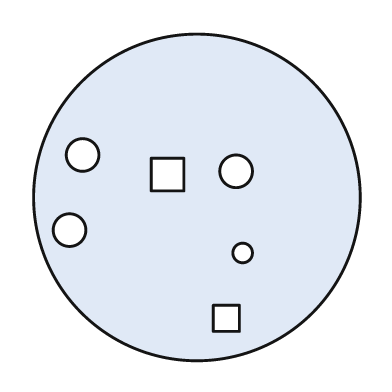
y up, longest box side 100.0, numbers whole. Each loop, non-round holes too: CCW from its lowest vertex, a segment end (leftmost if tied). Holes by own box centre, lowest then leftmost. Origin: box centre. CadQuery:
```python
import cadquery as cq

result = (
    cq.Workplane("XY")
    .moveTo(0.0, 0.0)
    .circle(50.0)
    .moveTo(5.0, -41.0)
    .lineTo(13.0, -41.0)
    .lineTo(13.0, -33.0)
    .lineTo(5.0, -33.0)
    .close()
    .moveTo(14.0, -17.0)
    .circle(3.0)
    .moveTo(-39.0, -10.0)
    .circle(5.0)
    .moveTo(-14.0, 2.0)
    .lineTo(-4.0, 2.0)
    .lineTo(-4.0, 12.0)
    .lineTo(-14.0, 12.0)
    .close()
    .moveTo(12.0, 8.0)
    .circle(5.0)
    .moveTo(-35.0, 13.0)
    .circle(5.0)
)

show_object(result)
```